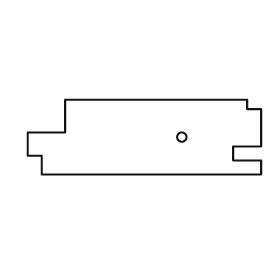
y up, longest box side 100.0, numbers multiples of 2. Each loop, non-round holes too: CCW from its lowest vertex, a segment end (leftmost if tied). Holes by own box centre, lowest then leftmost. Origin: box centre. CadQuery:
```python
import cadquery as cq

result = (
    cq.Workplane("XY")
    .moveTo(-44.0, -16.0)
    .lineTo(50.0, -16.0)
    .lineTo(50.0, -10.0)
    .lineTo(38.0, -10.0)
    .lineTo(38.0, -4.0)
    .lineTo(50.0, -4.0)
    .lineTo(50.0, 12.0)
    .lineTo(44.0, 12.0)
    .lineTo(44.0, 16.0)
    .lineTo(-34.0, 16.0)
    .lineTo(-34.0, 2.0)
    .lineTo(-50.0, 2.0)
    .lineTo(-50.0, -8.0)
    .lineTo(-44.0, -8.0)
    .close()
    .moveTo(16.0, 0.0)
    .circle(2.0)
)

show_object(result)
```